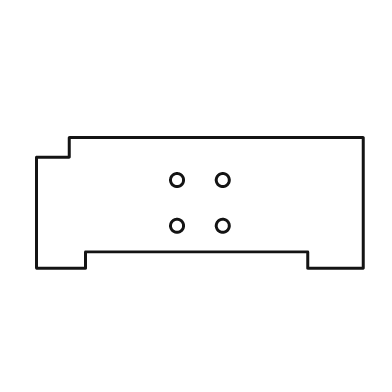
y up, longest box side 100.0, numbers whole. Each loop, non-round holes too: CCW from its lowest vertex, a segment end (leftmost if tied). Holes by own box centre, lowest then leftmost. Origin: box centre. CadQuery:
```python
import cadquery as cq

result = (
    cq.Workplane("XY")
    .moveTo(-50.0, -20.0)
    .lineTo(-35.0, -20.0)
    .lineTo(-35.0, -15.0)
    .lineTo(33.0, -15.0)
    .lineTo(33.0, -20.0)
    .lineTo(50.0, -20.0)
    .lineTo(50.0, 20.0)
    .lineTo(-40.0, 20.0)
    .lineTo(-40.0, 14.0)
    .lineTo(-50.0, 14.0)
    .close()
    .moveTo(-7.0, -7.0)
    .circle(2.0)
    .moveTo(7.0, -7.0)
    .circle(2.0)
    .moveTo(-7.0, 7.0)
    .circle(2.0)
    .moveTo(7.0, 7.0)
    .circle(2.0)
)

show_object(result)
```